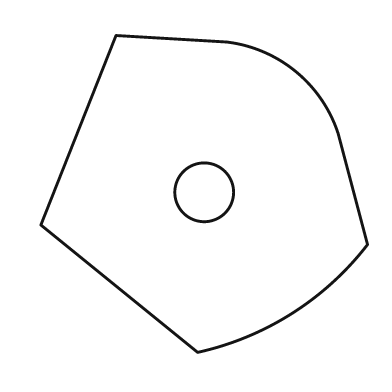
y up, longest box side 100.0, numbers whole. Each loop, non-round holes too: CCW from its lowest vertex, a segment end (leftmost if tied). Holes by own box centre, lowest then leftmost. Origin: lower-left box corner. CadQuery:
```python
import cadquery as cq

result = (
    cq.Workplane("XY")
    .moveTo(48.0, 0.0)
    .threePointArc((77.0, 12.0), (100.0, 33.0))
    .lineTo(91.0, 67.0)
    .threePointArc((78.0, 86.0), (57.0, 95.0))
    .lineTo(23.0, 97.0)
    .lineTo(0.0, 39.0)
    .close()
    .moveTo(50.0, 49.0)
    .circle(9.0)
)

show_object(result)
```